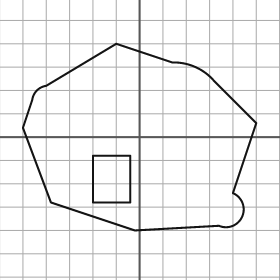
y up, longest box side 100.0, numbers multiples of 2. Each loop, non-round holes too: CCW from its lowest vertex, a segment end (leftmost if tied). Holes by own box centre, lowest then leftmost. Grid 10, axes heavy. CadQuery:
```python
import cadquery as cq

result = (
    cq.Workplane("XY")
    .moveTo(-2.0, -40.0)
    .lineTo(34.0, -38.0)
    .threePointArc((44.0, -34.0), (40.0, -24.0))
    .lineTo(50.0, 6.0)
    .lineTo(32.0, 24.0)
    .threePointArc((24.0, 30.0), (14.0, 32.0))
    .lineTo(-10.0, 40.0)
    .lineTo(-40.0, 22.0)
    .threePointArc((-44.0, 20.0), (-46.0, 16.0))
    .lineTo(-50.0, 4.0)
    .lineTo(-38.0, -28.0)
    .close()
    .moveTo(-20.0, -28.0)
    .lineTo(-4.0, -28.0)
    .lineTo(-4.0, -8.0)
    .lineTo(-20.0, -8.0)
    .close()
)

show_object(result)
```